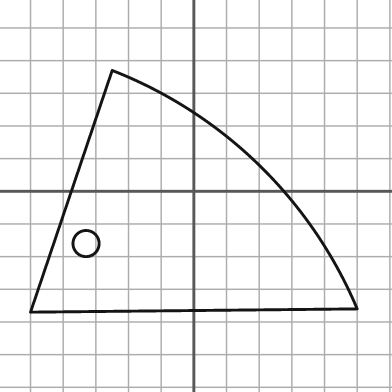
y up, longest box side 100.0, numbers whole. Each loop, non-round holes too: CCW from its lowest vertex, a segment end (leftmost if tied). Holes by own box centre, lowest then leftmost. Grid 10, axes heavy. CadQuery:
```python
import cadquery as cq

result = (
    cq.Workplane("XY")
    .moveTo(-50.0, -37.0)
    .lineTo(50.0, -36.0)
    .threePointArc((20.0, 8.0), (-25.0, 37.0))
    .close()
    .moveTo(-33.0, -16.0)
    .circle(4.0)
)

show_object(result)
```